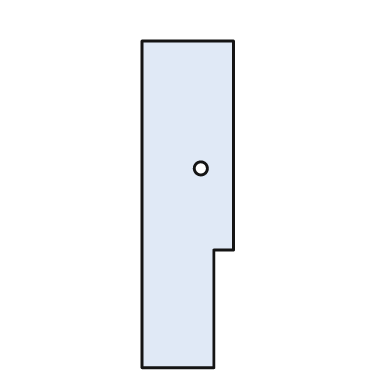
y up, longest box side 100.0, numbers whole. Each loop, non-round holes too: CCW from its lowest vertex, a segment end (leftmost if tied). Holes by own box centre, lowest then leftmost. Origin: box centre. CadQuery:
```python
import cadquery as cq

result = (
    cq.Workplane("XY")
    .moveTo(-14.0, -50.0)
    .lineTo(8.0, -50.0)
    .lineTo(8.0, -14.0)
    .lineTo(14.0, -14.0)
    .lineTo(14.0, 50.0)
    .lineTo(-14.0, 50.0)
    .close()
    .moveTo(4.0, 11.0)
    .circle(2.0)
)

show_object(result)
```